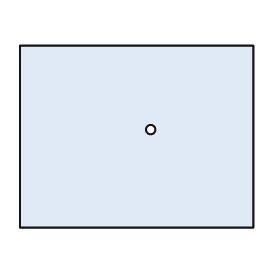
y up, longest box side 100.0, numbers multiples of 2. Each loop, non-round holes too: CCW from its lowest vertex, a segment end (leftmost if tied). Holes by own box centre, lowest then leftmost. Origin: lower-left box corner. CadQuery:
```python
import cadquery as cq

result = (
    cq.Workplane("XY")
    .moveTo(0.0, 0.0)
    .lineTo(100.0, 0.0)
    .lineTo(100.0, 78.0)
    .lineTo(0.0, 78.0)
    .close()
    .moveTo(56.0, 42.0)
    .circle(2.0)
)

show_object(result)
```